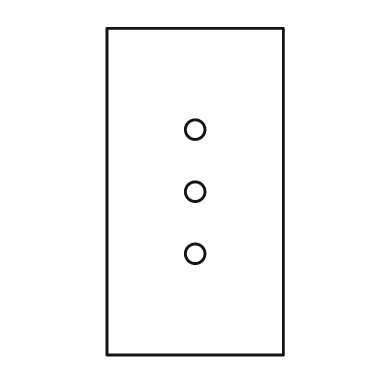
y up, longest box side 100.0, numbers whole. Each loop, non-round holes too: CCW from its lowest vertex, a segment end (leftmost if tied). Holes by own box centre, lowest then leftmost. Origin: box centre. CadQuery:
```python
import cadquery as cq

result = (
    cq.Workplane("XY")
    .moveTo(-27.0, -50.0)
    .lineTo(27.0, -50.0)
    .lineTo(27.0, 50.0)
    .lineTo(-27.0, 50.0)
    .close()
    .moveTo(0.0, -19.0)
    .circle(3.0)
    .moveTo(0.0, 0.0)
    .circle(3.0)
    .moveTo(0.0, 19.0)
    .circle(3.0)
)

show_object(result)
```